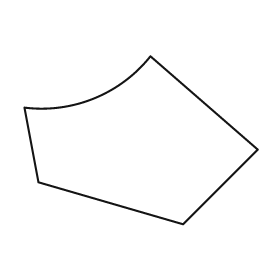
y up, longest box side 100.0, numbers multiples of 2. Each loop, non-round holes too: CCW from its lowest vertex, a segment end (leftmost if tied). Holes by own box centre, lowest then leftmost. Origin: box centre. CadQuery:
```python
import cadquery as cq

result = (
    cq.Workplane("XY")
    .moveTo(18.0, -36.0)
    .lineTo(50.0, -4.0)
    .lineTo(4.0, 36.0)
    .threePointArc((-20.0, 18.0), (-50.0, 14.0))
    .lineTo(-44.0, -18.0)
    .close()
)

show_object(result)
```